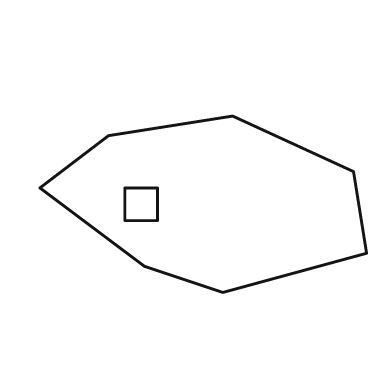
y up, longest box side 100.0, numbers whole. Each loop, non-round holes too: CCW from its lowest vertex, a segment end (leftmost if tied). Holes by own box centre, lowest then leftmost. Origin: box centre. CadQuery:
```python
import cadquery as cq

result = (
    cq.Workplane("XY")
    .moveTo(6.0, -27.0)
    .lineTo(50.0, -15.0)
    .lineTo(46.0, 10.0)
    .lineTo(9.0, 27.0)
    .lineTo(-29.0, 21.0)
    .lineTo(-50.0, 5.0)
    .lineTo(-18.0, -19.0)
    .close()
    .moveTo(-24.0, -5.0)
    .lineTo(-14.0, -5.0)
    .lineTo(-14.0, 5.0)
    .lineTo(-24.0, 5.0)
    .close()
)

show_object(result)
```